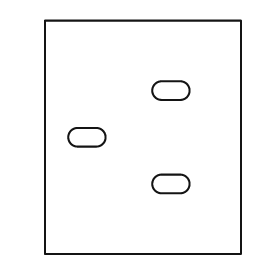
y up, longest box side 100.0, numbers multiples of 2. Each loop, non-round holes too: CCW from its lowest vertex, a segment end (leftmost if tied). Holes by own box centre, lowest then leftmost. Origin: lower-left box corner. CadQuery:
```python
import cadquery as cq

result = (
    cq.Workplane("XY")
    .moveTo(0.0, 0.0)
    .lineTo(84.0, 0.0)
    .lineTo(84.0, 100.0)
    .lineTo(0.0, 100.0)
    .close()
    .moveTo(50.0, 26.0)
    .lineTo(58.0, 26.0)
    .threePointArc((62.0, 30.0), (58.0, 34.0))
    .lineTo(50.0, 34.0)
    .threePointArc((46.0, 30.0), (50.0, 26.0))
    .close()
    .moveTo(14.0, 46.0)
    .lineTo(22.0, 46.0)
    .threePointArc((26.0, 50.0), (22.0, 54.0))
    .lineTo(14.0, 54.0)
    .threePointArc((10.0, 50.0), (14.0, 46.0))
    .close()
    .moveTo(50.0, 66.0)
    .lineTo(58.0, 66.0)
    .threePointArc((62.0, 70.0), (58.0, 74.0))
    .lineTo(50.0, 74.0)
    .threePointArc((46.0, 70.0), (50.0, 66.0))
    .close()
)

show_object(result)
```